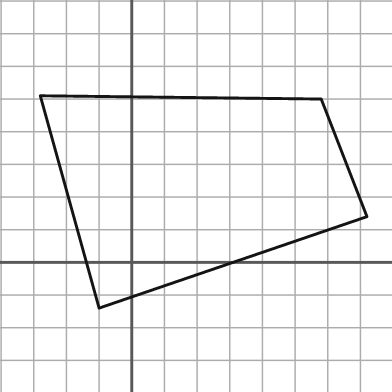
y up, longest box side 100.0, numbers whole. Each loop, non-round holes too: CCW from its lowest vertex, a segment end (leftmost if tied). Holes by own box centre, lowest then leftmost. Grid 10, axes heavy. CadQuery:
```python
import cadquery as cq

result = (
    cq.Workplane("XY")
    .moveTo(-10.0, -14.0)
    .lineTo(72.0, 14.0)
    .lineTo(58.0, 50.0)
    .lineTo(-28.0, 51.0)
    .close()
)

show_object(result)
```